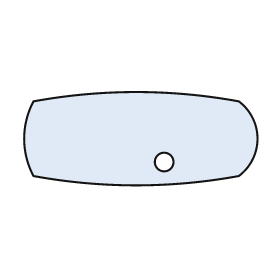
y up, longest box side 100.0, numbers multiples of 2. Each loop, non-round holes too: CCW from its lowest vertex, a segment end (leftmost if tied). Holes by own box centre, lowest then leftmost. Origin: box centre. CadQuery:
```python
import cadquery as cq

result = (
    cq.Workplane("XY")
    .moveTo(-46.0, -16.0)
    .threePointArc((-2.0, -20.0), (42.0, -16.0))
    .threePointArc((50.0, 0.0), (42.0, 16.0))
    .threePointArc((-2.0, 20.0), (-46.0, 16.0))
    .threePointArc((-50.0, 0.0), (-46.0, -16.0))
    .close()
    .moveTo(10.0, -10.0)
    .circle(4.0)
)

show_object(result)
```